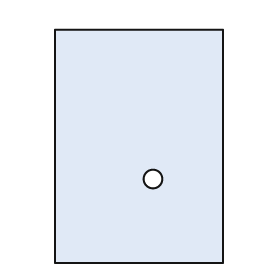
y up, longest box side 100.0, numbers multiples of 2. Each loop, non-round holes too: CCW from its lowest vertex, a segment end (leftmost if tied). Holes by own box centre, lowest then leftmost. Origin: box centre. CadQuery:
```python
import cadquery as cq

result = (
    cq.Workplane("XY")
    .moveTo(-36.0, -50.0)
    .lineTo(36.0, -50.0)
    .lineTo(36.0, 50.0)
    .lineTo(-36.0, 50.0)
    .close()
    .moveTo(6.0, -14.0)
    .circle(4.0)
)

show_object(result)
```